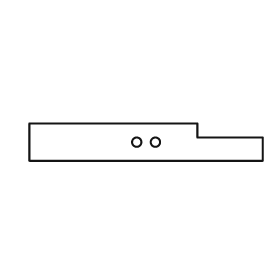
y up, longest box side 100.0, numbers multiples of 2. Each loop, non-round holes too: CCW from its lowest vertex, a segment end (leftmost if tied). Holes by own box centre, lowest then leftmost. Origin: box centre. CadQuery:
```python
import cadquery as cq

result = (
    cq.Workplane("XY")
    .moveTo(-50.0, -8.0)
    .lineTo(50.0, -8.0)
    .lineTo(50.0, 2.0)
    .lineTo(22.0, 2.0)
    .lineTo(22.0, 8.0)
    .lineTo(-50.0, 8.0)
    .close()
    .moveTo(-4.0, 0.0)
    .circle(2.0)
    .moveTo(4.0, 0.0)
    .circle(2.0)
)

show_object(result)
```